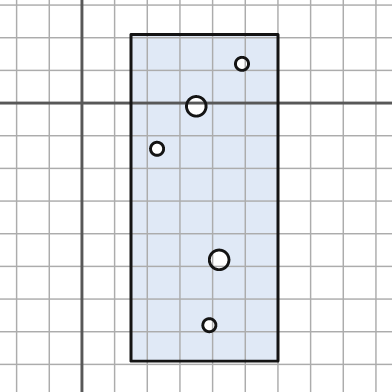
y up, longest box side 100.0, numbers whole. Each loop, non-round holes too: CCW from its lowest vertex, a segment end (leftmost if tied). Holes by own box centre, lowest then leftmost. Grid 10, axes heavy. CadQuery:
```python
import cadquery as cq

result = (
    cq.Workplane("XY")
    .moveTo(15.0, -79.0)
    .lineTo(60.0, -79.0)
    .lineTo(60.0, 21.0)
    .lineTo(15.0, 21.0)
    .close()
    .moveTo(39.0, -68.0)
    .circle(2.0)
    .moveTo(42.0, -48.0)
    .circle(3.0)
    .moveTo(23.0, -14.0)
    .circle(2.0)
    .moveTo(35.0, -1.0)
    .circle(3.0)
    .moveTo(49.0, 12.0)
    .circle(2.0)
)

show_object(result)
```